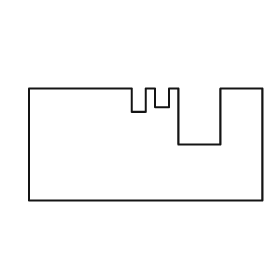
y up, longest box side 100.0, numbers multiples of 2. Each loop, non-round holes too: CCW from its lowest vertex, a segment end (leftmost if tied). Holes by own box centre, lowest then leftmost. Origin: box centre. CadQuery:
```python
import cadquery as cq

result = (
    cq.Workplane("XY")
    .moveTo(-50.0, -24.0)
    .lineTo(50.0, -24.0)
    .lineTo(50.0, 24.0)
    .lineTo(32.0, 24.0)
    .lineTo(32.0, 0.0)
    .lineTo(14.0, 0.0)
    .lineTo(14.0, 24.0)
    .lineTo(10.0, 24.0)
    .lineTo(10.0, 16.0)
    .lineTo(4.0, 16.0)
    .lineTo(4.0, 24.0)
    .lineTo(0.0, 24.0)
    .lineTo(0.0, 14.0)
    .lineTo(-6.0, 14.0)
    .lineTo(-6.0, 24.0)
    .lineTo(-50.0, 24.0)
    .close()
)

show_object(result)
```